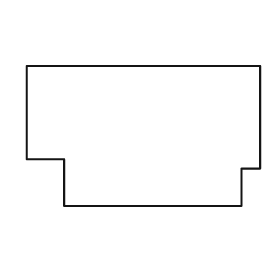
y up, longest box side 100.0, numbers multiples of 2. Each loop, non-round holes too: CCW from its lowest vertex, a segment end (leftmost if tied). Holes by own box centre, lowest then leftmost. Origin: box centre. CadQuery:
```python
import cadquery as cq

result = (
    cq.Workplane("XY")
    .moveTo(-34.0, -30.0)
    .lineTo(42.0, -30.0)
    .lineTo(42.0, -14.0)
    .lineTo(50.0, -14.0)
    .lineTo(50.0, 30.0)
    .lineTo(-50.0, 30.0)
    .lineTo(-50.0, -10.0)
    .lineTo(-34.0, -10.0)
    .close()
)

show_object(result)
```